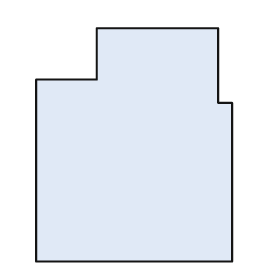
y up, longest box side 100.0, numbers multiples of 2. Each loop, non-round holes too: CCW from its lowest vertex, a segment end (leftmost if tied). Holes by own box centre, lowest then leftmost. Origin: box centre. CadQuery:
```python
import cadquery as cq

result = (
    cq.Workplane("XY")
    .moveTo(-42.0, -50.0)
    .lineTo(42.0, -50.0)
    .lineTo(42.0, 18.0)
    .lineTo(36.0, 18.0)
    .lineTo(36.0, 50.0)
    .lineTo(-16.0, 50.0)
    .lineTo(-16.0, 28.0)
    .lineTo(-42.0, 28.0)
    .close()
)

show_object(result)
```